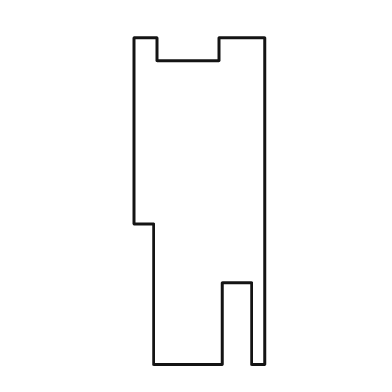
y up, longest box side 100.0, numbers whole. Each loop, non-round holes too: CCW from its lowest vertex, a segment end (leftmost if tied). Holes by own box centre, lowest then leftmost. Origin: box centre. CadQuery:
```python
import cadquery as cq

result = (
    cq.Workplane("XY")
    .moveTo(-14.0, -50.0)
    .lineTo(7.0, -50.0)
    .lineTo(7.0, -25.0)
    .lineTo(16.0, -25.0)
    .lineTo(16.0, -50.0)
    .lineTo(20.0, -50.0)
    .lineTo(20.0, 50.0)
    .lineTo(6.0, 50.0)
    .lineTo(6.0, 43.0)
    .lineTo(-13.0, 43.0)
    .lineTo(-13.0, 50.0)
    .lineTo(-20.0, 50.0)
    .lineTo(-20.0, -7.0)
    .lineTo(-14.0, -7.0)
    .close()
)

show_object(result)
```